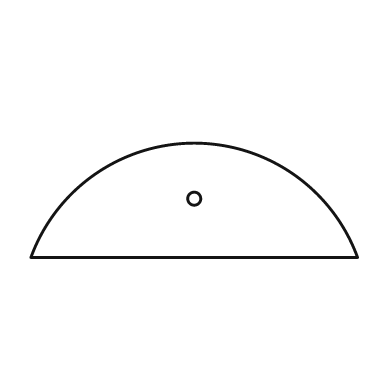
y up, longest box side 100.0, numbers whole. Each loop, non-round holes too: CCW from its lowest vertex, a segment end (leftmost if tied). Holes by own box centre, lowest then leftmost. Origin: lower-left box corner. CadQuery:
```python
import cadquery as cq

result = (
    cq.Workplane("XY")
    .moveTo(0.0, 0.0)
    .lineTo(100.0, 0.0)
    .threePointArc((50.0, 35.0), (0.0, 0.0))
    .close()
    .moveTo(50.0, 18.0)
    .circle(2.0)
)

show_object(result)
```